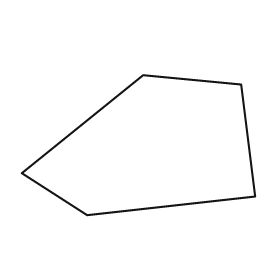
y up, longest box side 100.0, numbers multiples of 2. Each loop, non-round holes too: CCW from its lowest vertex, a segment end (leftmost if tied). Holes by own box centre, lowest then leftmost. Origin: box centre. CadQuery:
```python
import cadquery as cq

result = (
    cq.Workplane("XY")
    .moveTo(-22.0, -30.0)
    .lineTo(50.0, -22.0)
    .lineTo(44.0, 26.0)
    .lineTo(2.0, 30.0)
    .lineTo(-50.0, -12.0)
    .close()
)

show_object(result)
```